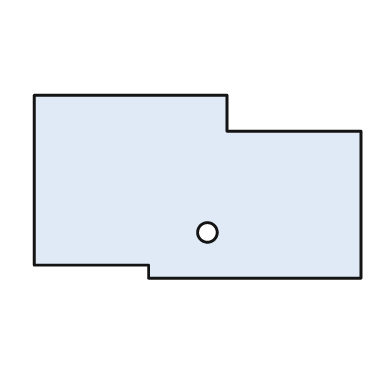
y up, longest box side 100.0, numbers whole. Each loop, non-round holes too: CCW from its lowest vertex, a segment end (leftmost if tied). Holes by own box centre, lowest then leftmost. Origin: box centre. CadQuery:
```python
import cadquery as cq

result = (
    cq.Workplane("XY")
    .moveTo(-15.0, -28.0)
    .lineTo(50.0, -28.0)
    .lineTo(50.0, 17.0)
    .lineTo(9.0, 17.0)
    .lineTo(9.0, 28.0)
    .lineTo(-50.0, 28.0)
    .lineTo(-50.0, -24.0)
    .lineTo(-15.0, -24.0)
    .close()
    .moveTo(3.0, -14.0)
    .circle(3.0)
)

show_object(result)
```